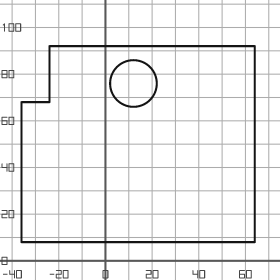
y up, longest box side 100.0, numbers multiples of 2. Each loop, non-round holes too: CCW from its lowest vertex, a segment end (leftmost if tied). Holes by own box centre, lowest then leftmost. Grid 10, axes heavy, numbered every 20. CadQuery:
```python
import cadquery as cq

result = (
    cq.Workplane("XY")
    .moveTo(-36.0, 8.0)
    .lineTo(64.0, 8.0)
    .lineTo(64.0, 92.0)
    .lineTo(-24.0, 92.0)
    .lineTo(-24.0, 68.0)
    .lineTo(-36.0, 68.0)
    .close()
    .moveTo(12.0, 76.0)
    .circle(10.0)
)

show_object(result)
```